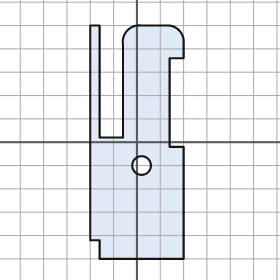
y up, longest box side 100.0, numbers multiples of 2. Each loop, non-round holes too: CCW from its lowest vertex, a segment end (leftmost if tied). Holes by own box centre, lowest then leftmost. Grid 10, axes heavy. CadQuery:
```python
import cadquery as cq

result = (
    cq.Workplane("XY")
    .moveTo(-16.0, -50.0)
    .lineTo(20.0, -50.0)
    .lineTo(20.0, -2.0)
    .lineTo(14.0, -2.0)
    .lineTo(14.0, 36.0)
    .lineTo(20.0, 36.0)
    .lineTo(20.0, 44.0)
    .threePointArc((18.0, 48.0), (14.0, 50.0))
    .lineTo(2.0, 50.0)
    .threePointArc((-4.0, 48.0), (-6.0, 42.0))
    .lineTo(-6.0, 2.0)
    .lineTo(-16.0, 2.0)
    .lineTo(-16.0, 50.0)
    .lineTo(-20.0, 50.0)
    .lineTo(-20.0, -42.0)
    .lineTo(-16.0, -42.0)
    .close()
    .moveTo(2.0, -10.0)
    .circle(4.0)
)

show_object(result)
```